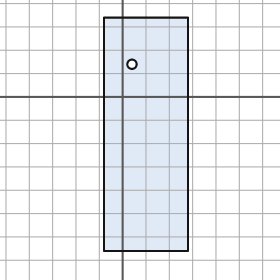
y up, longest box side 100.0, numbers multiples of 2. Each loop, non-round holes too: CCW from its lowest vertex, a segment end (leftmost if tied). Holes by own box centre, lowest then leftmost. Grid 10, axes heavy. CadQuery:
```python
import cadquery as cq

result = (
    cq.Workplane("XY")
    .moveTo(-8.0, -66.0)
    .lineTo(28.0, -66.0)
    .lineTo(28.0, 34.0)
    .lineTo(-8.0, 34.0)
    .close()
    .moveTo(4.0, 14.0)
    .circle(2.0)
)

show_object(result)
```